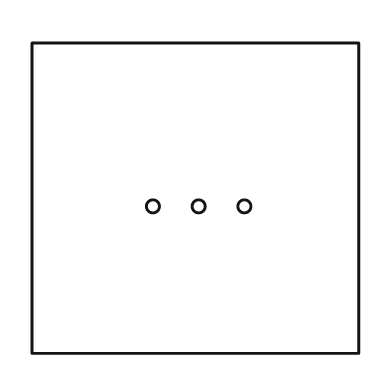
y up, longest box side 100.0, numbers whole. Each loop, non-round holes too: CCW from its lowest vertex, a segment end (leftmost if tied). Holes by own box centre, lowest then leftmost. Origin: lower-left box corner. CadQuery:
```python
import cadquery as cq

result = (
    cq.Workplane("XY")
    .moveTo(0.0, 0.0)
    .lineTo(100.0, 0.0)
    .lineTo(100.0, 95.0)
    .lineTo(0.0, 95.0)
    .close()
    .moveTo(37.0, 45.0)
    .circle(2.0)
    .moveTo(51.0, 45.0)
    .circle(2.0)
    .moveTo(65.0, 45.0)
    .circle(2.0)
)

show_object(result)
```